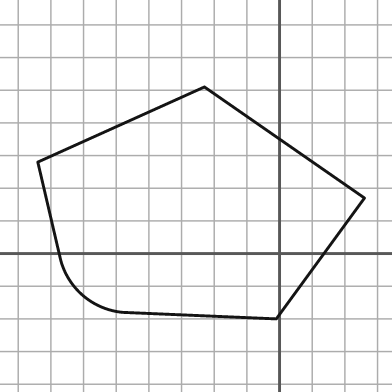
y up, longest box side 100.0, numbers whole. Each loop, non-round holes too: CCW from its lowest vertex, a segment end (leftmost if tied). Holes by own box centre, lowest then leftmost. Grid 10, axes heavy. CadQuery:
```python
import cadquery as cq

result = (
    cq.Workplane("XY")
    .moveTo(-1.0, -20.0)
    .lineTo(26.0, 17.0)
    .lineTo(-23.0, 51.0)
    .lineTo(-74.0, 28.0)
    .lineTo(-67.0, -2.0)
    .threePointArc((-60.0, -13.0), (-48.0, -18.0))
    .close()
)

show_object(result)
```